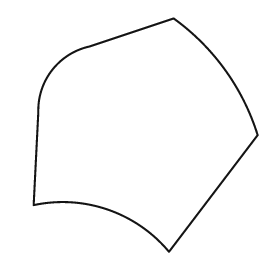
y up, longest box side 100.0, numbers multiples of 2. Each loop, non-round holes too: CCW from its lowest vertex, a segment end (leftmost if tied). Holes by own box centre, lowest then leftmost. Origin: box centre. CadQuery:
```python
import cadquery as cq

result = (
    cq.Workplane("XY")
    .moveTo(10.0, -50.0)
    .lineTo(48.0, 0.0)
    .threePointArc((34.0, 28.0), (12.0, 50.0))
    .lineTo(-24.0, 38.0)
    .threePointArc((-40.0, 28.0), (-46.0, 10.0))
    .lineTo(-48.0, -30.0)
    .threePointArc((-16.0, -32.0), (10.0, -50.0))
    .close()
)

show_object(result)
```